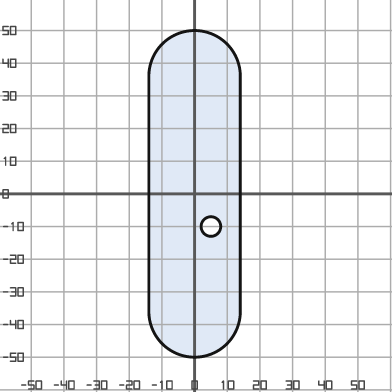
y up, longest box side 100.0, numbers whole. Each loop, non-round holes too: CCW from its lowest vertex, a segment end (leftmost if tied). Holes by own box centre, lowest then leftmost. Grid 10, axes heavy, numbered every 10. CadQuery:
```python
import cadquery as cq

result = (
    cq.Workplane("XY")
    .moveTo(-14.0, -36.0)
    .threePointArc((0.0, -50.0), (14.0, -36.0))
    .lineTo(14.0, 36.0)
    .threePointArc((0.0, 50.0), (-14.0, 36.0))
    .close()
    .moveTo(5.0, -10.0)
    .circle(3.0)
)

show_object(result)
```